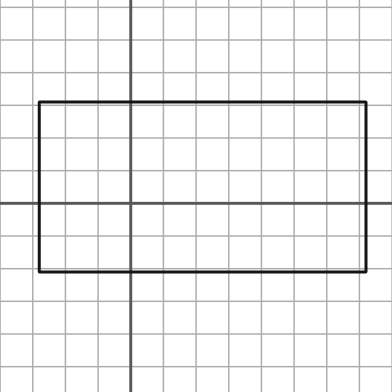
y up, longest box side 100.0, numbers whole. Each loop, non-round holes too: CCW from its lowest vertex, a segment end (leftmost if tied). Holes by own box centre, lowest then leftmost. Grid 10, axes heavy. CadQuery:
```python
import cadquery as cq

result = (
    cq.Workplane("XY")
    .moveTo(-28.0, -21.0)
    .lineTo(72.0, -21.0)
    .lineTo(72.0, 31.0)
    .lineTo(-28.0, 31.0)
    .close()
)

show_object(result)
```